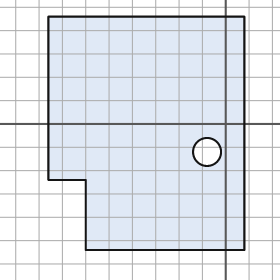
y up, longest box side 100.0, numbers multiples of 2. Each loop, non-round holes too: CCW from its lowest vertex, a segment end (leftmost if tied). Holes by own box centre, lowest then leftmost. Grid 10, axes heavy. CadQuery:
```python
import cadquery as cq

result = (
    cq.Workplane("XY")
    .moveTo(-60.0, -54.0)
    .lineTo(8.0, -54.0)
    .lineTo(8.0, 46.0)
    .lineTo(-76.0, 46.0)
    .lineTo(-76.0, -24.0)
    .lineTo(-60.0, -24.0)
    .close()
    .moveTo(-8.0, -12.0)
    .circle(6.0)
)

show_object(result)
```